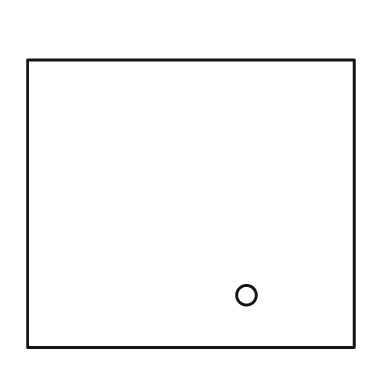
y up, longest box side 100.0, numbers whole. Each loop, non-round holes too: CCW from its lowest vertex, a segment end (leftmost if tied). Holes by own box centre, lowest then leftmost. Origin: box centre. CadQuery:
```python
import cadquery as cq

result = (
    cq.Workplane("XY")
    .moveTo(-50.0, -44.0)
    .lineTo(50.0, -44.0)
    .lineTo(50.0, 44.0)
    .lineTo(-50.0, 44.0)
    .close()
    .moveTo(17.0, -28.0)
    .circle(3.0)
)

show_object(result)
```